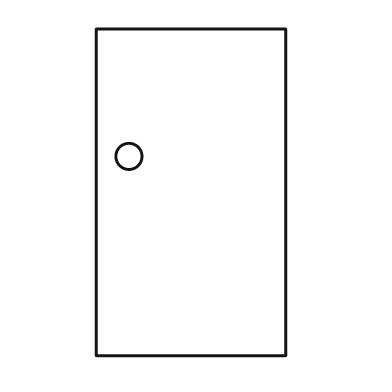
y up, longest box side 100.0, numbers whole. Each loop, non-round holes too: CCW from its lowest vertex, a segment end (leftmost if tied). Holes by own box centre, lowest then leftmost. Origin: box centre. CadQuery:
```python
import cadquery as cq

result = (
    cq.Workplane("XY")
    .moveTo(-29.0, -50.0)
    .lineTo(29.0, -50.0)
    .lineTo(29.0, 50.0)
    .lineTo(-29.0, 50.0)
    .close()
    .moveTo(-19.0, 11.0)
    .circle(4.0)
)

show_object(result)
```